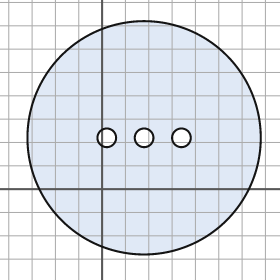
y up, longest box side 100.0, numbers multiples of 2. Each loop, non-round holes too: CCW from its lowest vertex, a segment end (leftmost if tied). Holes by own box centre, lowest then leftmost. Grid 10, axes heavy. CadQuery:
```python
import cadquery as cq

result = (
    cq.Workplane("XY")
    .moveTo(18.0, 22.0)
    .circle(50.0)
    .moveTo(2.0, 22.0)
    .circle(4.0)
    .moveTo(18.0, 22.0)
    .circle(4.0)
    .moveTo(34.0, 22.0)
    .circle(4.0)
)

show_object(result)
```